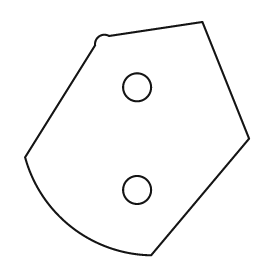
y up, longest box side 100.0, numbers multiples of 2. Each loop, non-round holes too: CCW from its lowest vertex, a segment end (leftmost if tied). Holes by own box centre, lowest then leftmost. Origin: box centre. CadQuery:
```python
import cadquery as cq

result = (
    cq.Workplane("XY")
    .moveTo(6.0, -50.0)
    .lineTo(48.0, 0.0)
    .lineTo(28.0, 50.0)
    .lineTo(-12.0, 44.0)
    .threePointArc((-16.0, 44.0), (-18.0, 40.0))
    .lineTo(-48.0, -8.0)
    .threePointArc((-28.0, -38.0), (6.0, -50.0))
    .close()
    .moveTo(0.0, -22.0)
    .circle(6.0)
    .moveTo(0.0, 22.0)
    .circle(6.0)
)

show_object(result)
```